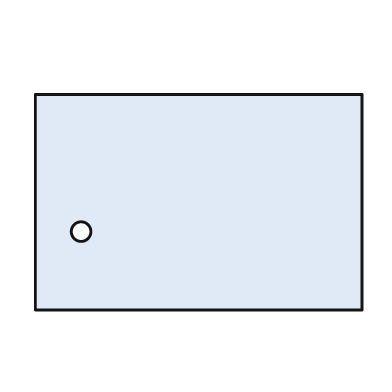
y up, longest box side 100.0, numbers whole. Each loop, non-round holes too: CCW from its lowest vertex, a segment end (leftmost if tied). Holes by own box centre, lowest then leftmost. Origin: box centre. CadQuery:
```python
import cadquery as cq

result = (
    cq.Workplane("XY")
    .moveTo(-50.0, -33.0)
    .lineTo(50.0, -33.0)
    .lineTo(50.0, 33.0)
    .lineTo(-50.0, 33.0)
    .close()
    .moveTo(-36.0, -9.0)
    .circle(3.0)
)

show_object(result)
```